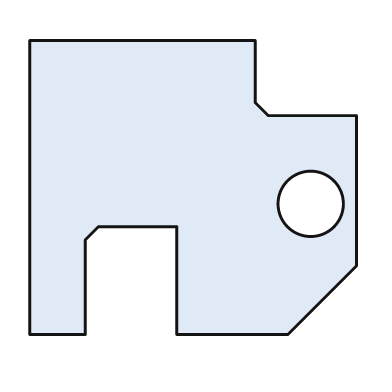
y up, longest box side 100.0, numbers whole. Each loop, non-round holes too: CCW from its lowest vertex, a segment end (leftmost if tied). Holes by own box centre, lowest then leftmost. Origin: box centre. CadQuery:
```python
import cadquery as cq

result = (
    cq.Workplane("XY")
    .moveTo(-50.0, -45.0)
    .lineTo(-33.0, -45.0)
    .lineTo(-33.0, -16.0)
    .lineTo(-29.0, -12.0)
    .lineTo(-5.0, -12.0)
    .lineTo(-5.0, -45.0)
    .lineTo(29.0, -45.0)
    .lineTo(50.0, -24.0)
    .lineTo(50.0, 22.0)
    .lineTo(23.0, 22.0)
    .lineTo(19.0, 26.0)
    .lineTo(19.0, 45.0)
    .lineTo(-50.0, 45.0)
    .close()
    .moveTo(36.0, -5.0)
    .circle(10.0)
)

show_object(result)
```